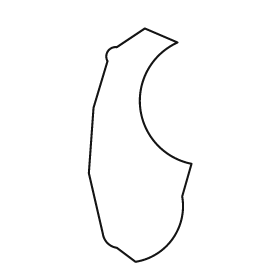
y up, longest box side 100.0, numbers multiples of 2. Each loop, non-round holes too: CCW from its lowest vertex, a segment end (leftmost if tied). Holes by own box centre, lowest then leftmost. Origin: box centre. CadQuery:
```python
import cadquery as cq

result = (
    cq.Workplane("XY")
    .moveTo(-2.0, -50.0)
    .threePointArc((14.0, -40.0), (18.0, -22.0))
    .lineTo(22.0, -8.0)
    .threePointArc((0.0, 16.0), (16.0, 44.0))
    .lineTo(2.0, 50.0)
    .lineTo(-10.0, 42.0)
    .threePointArc((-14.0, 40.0), (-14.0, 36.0))
    .lineTo(-20.0, 16.0)
    .lineTo(-22.0, -12.0)
    .lineTo(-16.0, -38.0)
    .threePointArc((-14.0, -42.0), (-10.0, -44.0))
    .close()
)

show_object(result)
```